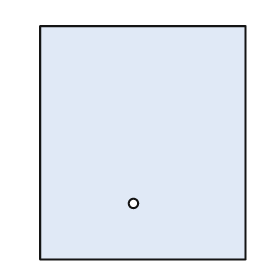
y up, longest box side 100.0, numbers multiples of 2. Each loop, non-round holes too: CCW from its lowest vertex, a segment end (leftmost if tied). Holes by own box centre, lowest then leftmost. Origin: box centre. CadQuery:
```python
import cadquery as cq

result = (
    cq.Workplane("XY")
    .moveTo(-44.0, -50.0)
    .lineTo(44.0, -50.0)
    .lineTo(44.0, 50.0)
    .lineTo(-44.0, 50.0)
    .close()
    .moveTo(-4.0, -26.0)
    .circle(2.0)
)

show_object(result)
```